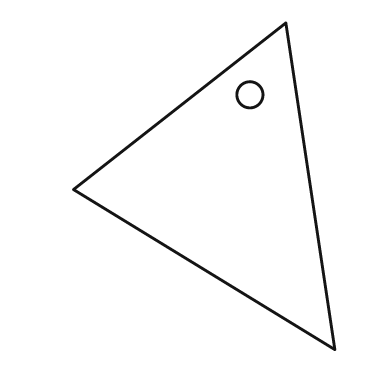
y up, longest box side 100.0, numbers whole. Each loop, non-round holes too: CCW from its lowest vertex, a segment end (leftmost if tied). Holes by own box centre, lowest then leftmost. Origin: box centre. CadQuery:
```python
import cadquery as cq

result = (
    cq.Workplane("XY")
    .moveTo(40.0, -50.0)
    .lineTo(25.0, 50.0)
    .lineTo(-40.0, -1.0)
    .close()
    .moveTo(14.0, 28.0)
    .circle(4.0)
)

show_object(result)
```